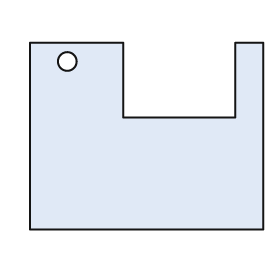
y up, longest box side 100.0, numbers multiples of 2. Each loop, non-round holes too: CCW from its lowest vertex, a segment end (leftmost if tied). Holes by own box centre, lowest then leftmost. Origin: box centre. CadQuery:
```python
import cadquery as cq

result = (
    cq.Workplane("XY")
    .moveTo(-50.0, -40.0)
    .lineTo(50.0, -40.0)
    .lineTo(50.0, 40.0)
    .lineTo(38.0, 40.0)
    .lineTo(38.0, 8.0)
    .lineTo(-10.0, 8.0)
    .lineTo(-10.0, 40.0)
    .lineTo(-50.0, 40.0)
    .close()
    .moveTo(-34.0, 32.0)
    .circle(4.0)
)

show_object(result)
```